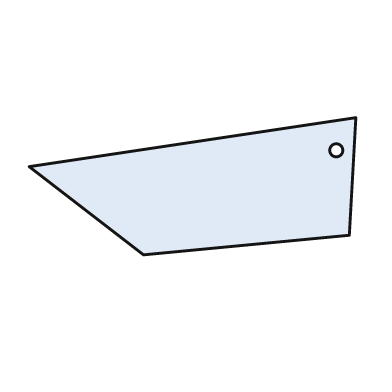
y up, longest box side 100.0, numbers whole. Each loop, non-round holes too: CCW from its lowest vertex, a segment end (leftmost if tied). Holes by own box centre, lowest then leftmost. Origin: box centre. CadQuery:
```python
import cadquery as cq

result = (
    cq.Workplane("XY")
    .moveTo(-15.0, -21.0)
    .lineTo(48.0, -15.0)
    .lineTo(50.0, 21.0)
    .lineTo(-50.0, 6.0)
    .close()
    .moveTo(44.0, 11.0)
    .circle(2.0)
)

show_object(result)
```